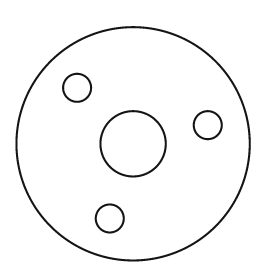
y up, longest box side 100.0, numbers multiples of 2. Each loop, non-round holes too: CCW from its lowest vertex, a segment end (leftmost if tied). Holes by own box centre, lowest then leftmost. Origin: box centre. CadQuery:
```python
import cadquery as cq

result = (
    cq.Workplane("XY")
    .moveTo(0.0, 0.0)
    .circle(50.0)
    .moveTo(-10.0, -32.0)
    .circle(6.0)
    .moveTo(0.0, 0.0)
    .circle(14.0)
    .moveTo(32.0, 8.0)
    .circle(6.0)
    .moveTo(-24.0, 24.0)
    .circle(6.0)
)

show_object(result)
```